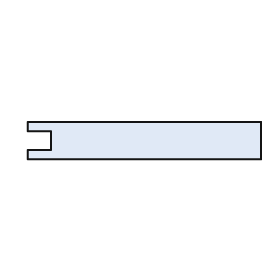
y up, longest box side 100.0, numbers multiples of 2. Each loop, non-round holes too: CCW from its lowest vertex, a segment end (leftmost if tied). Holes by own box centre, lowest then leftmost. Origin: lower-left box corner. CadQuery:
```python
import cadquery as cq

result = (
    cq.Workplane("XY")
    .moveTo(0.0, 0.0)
    .lineTo(100.0, 0.0)
    .lineTo(100.0, 16.0)
    .lineTo(0.0, 16.0)
    .lineTo(0.0, 12.0)
    .lineTo(10.0, 12.0)
    .lineTo(10.0, 4.0)
    .lineTo(0.0, 4.0)
    .close()
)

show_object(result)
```